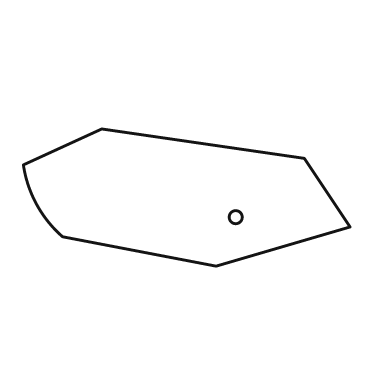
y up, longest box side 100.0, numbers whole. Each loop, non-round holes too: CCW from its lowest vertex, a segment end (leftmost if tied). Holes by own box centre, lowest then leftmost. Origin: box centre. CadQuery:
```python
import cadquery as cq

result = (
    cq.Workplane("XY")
    .moveTo(9.0, -21.0)
    .lineTo(50.0, -9.0)
    .lineTo(36.0, 12.0)
    .lineTo(-26.0, 21.0)
    .lineTo(-50.0, 10.0)
    .threePointArc((-46.0, -2.0), (-38.0, -12.0))
    .close()
    .moveTo(15.0, -6.0)
    .circle(2.0)
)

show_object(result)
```